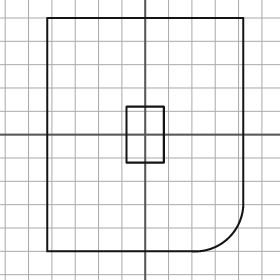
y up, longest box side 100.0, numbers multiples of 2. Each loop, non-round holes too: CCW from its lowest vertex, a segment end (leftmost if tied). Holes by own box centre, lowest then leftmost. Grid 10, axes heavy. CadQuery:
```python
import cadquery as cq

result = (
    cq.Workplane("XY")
    .moveTo(-42.0, -50.0)
    .lineTo(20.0, -50.0)
    .threePointArc((36.0, -44.0), (42.0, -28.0))
    .lineTo(42.0, 50.0)
    .lineTo(-42.0, 50.0)
    .close()
    .moveTo(-8.0, -12.0)
    .lineTo(8.0, -12.0)
    .lineTo(8.0, 12.0)
    .lineTo(-8.0, 12.0)
    .close()
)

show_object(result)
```